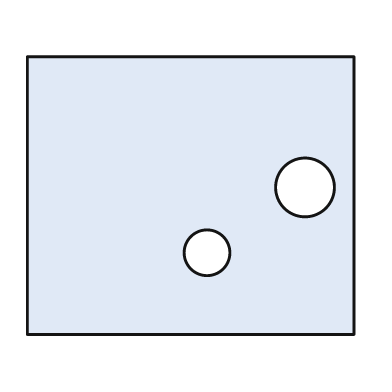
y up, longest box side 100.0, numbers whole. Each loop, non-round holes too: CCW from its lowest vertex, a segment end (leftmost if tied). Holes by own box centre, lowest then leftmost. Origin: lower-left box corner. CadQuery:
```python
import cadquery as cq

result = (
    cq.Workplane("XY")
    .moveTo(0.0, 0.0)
    .lineTo(100.0, 0.0)
    .lineTo(100.0, 85.0)
    .lineTo(0.0, 85.0)
    .close()
    .moveTo(55.0, 25.0)
    .circle(7.0)
    .moveTo(85.0, 45.0)
    .circle(9.0)
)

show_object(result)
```